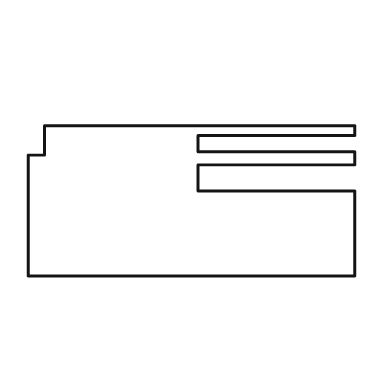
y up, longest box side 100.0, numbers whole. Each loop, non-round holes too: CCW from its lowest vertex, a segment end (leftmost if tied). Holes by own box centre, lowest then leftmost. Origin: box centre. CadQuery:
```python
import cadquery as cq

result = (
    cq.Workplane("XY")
    .moveTo(-50.0, -23.0)
    .lineTo(50.0, -23.0)
    .lineTo(50.0, 3.0)
    .lineTo(2.0, 3.0)
    .lineTo(2.0, 11.0)
    .lineTo(50.0, 11.0)
    .lineTo(50.0, 15.0)
    .lineTo(2.0, 15.0)
    .lineTo(2.0, 20.0)
    .lineTo(50.0, 20.0)
    .lineTo(50.0, 23.0)
    .lineTo(-45.0, 23.0)
    .lineTo(-45.0, 14.0)
    .lineTo(-50.0, 14.0)
    .close()
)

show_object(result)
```